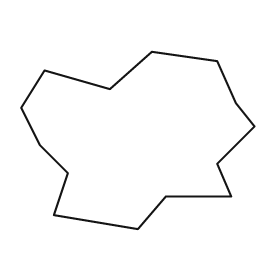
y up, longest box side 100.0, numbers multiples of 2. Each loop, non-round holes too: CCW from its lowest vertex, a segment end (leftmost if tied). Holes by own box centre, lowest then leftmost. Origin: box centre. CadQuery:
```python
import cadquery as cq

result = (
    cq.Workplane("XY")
    .moveTo(0.0, -38.0)
    .lineTo(12.0, -24.0)
    .lineTo(40.0, -24.0)
    .lineTo(34.0, -10.0)
    .lineTo(50.0, 6.0)
    .lineTo(42.0, 16.0)
    .lineTo(34.0, 34.0)
    .lineTo(6.0, 38.0)
    .lineTo(-12.0, 22.0)
    .lineTo(-40.0, 30.0)
    .lineTo(-50.0, 14.0)
    .lineTo(-42.0, -2.0)
    .lineTo(-30.0, -14.0)
    .lineTo(-36.0, -32.0)
    .close()
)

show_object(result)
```